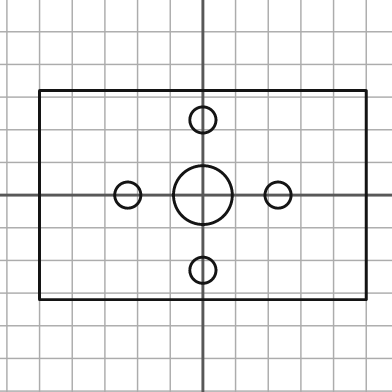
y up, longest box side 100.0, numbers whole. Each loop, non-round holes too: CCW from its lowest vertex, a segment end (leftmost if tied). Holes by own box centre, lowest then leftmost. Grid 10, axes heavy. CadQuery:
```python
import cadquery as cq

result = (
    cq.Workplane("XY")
    .moveTo(-50.0, -32.0)
    .lineTo(50.0, -32.0)
    .lineTo(50.0, 32.0)
    .lineTo(-50.0, 32.0)
    .close()
    .moveTo(0.0, -23.0)
    .circle(4.0)
    .moveTo(-23.0, 0.0)
    .circle(4.0)
    .moveTo(0.0, 0.0)
    .circle(9.0)
    .moveTo(23.0, 0.0)
    .circle(4.0)
    .moveTo(0.0, 23.0)
    .circle(4.0)
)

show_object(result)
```